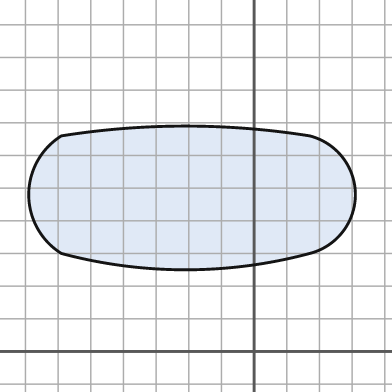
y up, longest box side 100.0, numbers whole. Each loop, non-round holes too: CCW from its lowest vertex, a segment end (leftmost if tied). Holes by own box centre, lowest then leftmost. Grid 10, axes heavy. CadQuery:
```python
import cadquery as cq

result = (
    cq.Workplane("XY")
    .moveTo(-59.0, 30.0)
    .threePointArc((-21.0, 25.0), (17.0, 30.0))
    .threePointArc((31.0, 48.0), (17.0, 66.0))
    .threePointArc((-21.0, 69.0), (-59.0, 66.0))
    .threePointArc((-69.0, 48.0), (-59.0, 30.0))
    .close()
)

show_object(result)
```